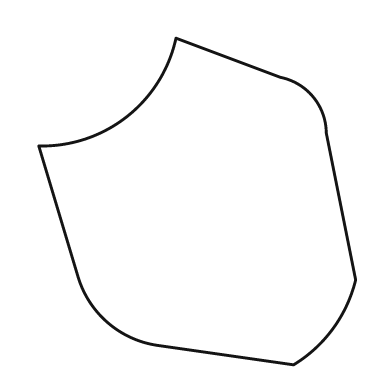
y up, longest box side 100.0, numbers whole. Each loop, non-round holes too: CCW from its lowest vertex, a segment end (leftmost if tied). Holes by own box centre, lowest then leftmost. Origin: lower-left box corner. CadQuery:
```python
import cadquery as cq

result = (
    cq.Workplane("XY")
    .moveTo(78.0, 0.0)
    .threePointArc((90.0, 11.0), (97.0, 26.0))
    .lineTo(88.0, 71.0)
    .threePointArc((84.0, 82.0), (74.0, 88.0))
    .lineTo(42.0, 100.0)
    .threePointArc((27.0, 76.0), (0.0, 67.0))
    .lineTo(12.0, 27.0)
    .threePointArc((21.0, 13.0), (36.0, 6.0))
    .close()
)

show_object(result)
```